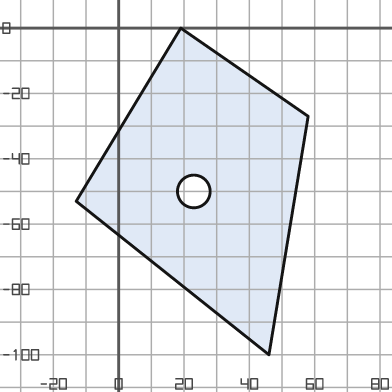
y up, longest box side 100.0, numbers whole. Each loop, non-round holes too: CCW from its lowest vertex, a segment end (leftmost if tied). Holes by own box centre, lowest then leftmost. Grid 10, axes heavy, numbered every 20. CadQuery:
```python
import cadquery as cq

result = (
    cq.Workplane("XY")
    .moveTo(46.0, -100.0)
    .lineTo(58.0, -27.0)
    .lineTo(19.0, 0.0)
    .lineTo(-13.0, -53.0)
    .close()
    .moveTo(23.0, -50.0)
    .circle(5.0)
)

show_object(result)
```